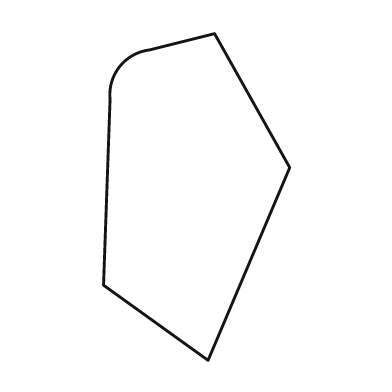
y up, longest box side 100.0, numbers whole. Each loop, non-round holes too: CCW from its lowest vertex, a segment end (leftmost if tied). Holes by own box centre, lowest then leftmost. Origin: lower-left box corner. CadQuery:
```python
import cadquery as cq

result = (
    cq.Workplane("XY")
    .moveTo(32.0, 0.0)
    .lineTo(57.0, 59.0)
    .lineTo(34.0, 100.0)
    .lineTo(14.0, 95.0)
    .threePointArc((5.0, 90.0), (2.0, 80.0))
    .lineTo(0.0, 23.0)
    .close()
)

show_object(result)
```